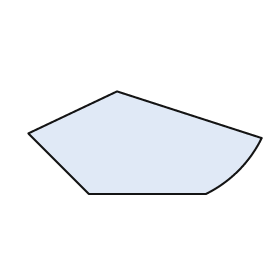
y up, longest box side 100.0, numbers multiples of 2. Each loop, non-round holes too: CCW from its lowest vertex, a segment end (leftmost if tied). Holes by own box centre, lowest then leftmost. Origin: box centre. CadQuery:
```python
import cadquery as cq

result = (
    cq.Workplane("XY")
    .moveTo(-24.0, -22.0)
    .lineTo(26.0, -22.0)
    .threePointArc((40.0, -12.0), (50.0, 2.0))
    .lineTo(-12.0, 22.0)
    .lineTo(-50.0, 4.0)
    .close()
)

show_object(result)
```